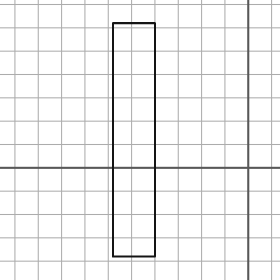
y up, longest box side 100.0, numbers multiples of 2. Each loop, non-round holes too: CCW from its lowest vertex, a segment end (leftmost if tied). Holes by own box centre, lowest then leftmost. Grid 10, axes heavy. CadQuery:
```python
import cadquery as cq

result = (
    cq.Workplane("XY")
    .moveTo(-58.0, -38.0)
    .lineTo(-40.0, -38.0)
    .lineTo(-40.0, 62.0)
    .lineTo(-58.0, 62.0)
    .close()
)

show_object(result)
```